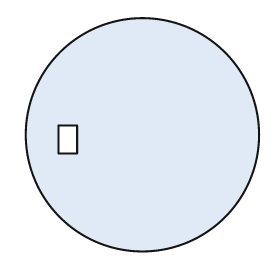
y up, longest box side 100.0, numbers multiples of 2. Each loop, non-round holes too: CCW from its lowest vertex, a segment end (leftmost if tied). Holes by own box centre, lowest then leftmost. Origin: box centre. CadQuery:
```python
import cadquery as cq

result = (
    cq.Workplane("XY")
    .moveTo(0.0, 0.0)
    .circle(50.0)
    .moveTo(-36.0, -8.0)
    .lineTo(-28.0, -8.0)
    .lineTo(-28.0, 4.0)
    .lineTo(-36.0, 4.0)
    .close()
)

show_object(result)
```